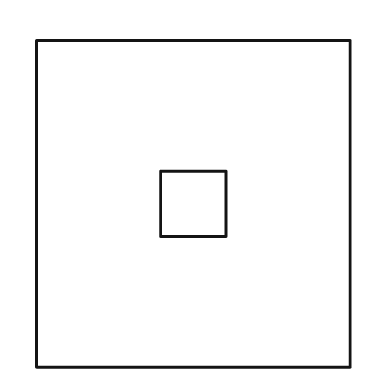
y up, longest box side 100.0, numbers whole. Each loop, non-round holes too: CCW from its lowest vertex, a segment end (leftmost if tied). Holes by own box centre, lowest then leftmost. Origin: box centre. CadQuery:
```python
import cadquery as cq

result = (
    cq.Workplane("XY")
    .moveTo(-48.0, -50.0)
    .lineTo(48.0, -50.0)
    .lineTo(48.0, 50.0)
    .lineTo(-48.0, 50.0)
    .close()
    .moveTo(-10.0, -10.0)
    .lineTo(10.0, -10.0)
    .lineTo(10.0, 10.0)
    .lineTo(-10.0, 10.0)
    .close()
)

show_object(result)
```